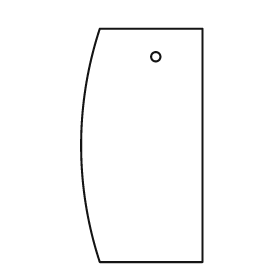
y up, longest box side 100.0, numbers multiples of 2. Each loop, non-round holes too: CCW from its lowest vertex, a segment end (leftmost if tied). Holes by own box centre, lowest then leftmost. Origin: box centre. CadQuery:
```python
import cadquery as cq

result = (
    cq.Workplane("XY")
    .moveTo(-18.0, -50.0)
    .lineTo(26.0, -50.0)
    .lineTo(26.0, 50.0)
    .lineTo(-18.0, 50.0)
    .threePointArc((-26.0, 0.0), (-18.0, -50.0))
    .close()
    .moveTo(6.0, 38.0)
    .circle(2.0)
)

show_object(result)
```